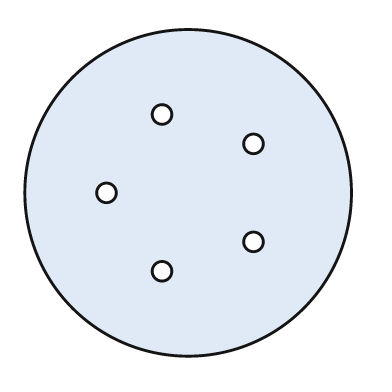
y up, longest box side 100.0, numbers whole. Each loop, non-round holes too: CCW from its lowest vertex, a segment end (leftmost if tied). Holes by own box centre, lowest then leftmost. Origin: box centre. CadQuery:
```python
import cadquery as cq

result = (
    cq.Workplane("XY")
    .moveTo(0.0, 0.0)
    .circle(50.0)
    .moveTo(-8.0, -24.0)
    .circle(3.0)
    .moveTo(20.0, -15.0)
    .circle(3.0)
    .moveTo(-25.0, 0.0)
    .circle(3.0)
    .moveTo(20.0, 15.0)
    .circle(3.0)
    .moveTo(-8.0, 24.0)
    .circle(3.0)
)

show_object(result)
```